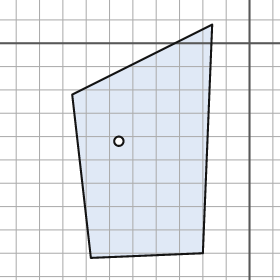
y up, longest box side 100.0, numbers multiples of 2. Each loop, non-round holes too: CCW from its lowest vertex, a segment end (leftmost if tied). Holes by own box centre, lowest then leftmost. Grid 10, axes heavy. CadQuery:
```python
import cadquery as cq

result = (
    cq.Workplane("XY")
    .moveTo(-68.0, -92.0)
    .lineTo(-20.0, -90.0)
    .lineTo(-16.0, 8.0)
    .lineTo(-76.0, -22.0)
    .close()
    .moveTo(-56.0, -42.0)
    .circle(2.0)
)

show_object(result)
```